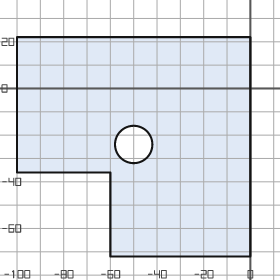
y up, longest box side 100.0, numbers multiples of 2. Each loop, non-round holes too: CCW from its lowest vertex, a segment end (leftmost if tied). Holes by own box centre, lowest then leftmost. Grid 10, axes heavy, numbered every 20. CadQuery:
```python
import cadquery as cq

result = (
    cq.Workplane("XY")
    .moveTo(-60.0, -72.0)
    .lineTo(0.0, -72.0)
    .lineTo(0.0, 22.0)
    .lineTo(-100.0, 22.0)
    .lineTo(-100.0, -36.0)
    .lineTo(-60.0, -36.0)
    .close()
    .moveTo(-50.0, -24.0)
    .circle(8.0)
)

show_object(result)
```